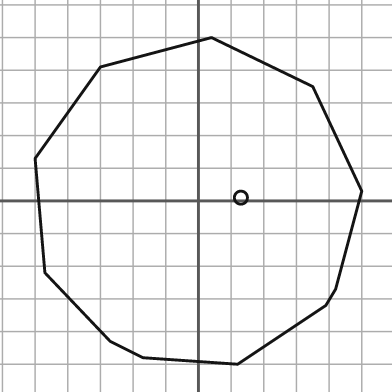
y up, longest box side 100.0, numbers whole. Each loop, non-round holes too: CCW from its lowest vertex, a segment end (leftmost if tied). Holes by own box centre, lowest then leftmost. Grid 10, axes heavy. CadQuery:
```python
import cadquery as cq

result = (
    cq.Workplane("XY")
    .moveTo(12.0, -50.0)
    .lineTo(39.0, -32.0)
    .lineTo(42.0, -27.0)
    .lineTo(50.0, 3.0)
    .lineTo(35.0, 35.0)
    .lineTo(4.0, 50.0)
    .lineTo(-30.0, 41.0)
    .lineTo(-50.0, 13.0)
    .lineTo(-47.0, -22.0)
    .lineTo(-27.0, -43.0)
    .lineTo(-17.0, -48.0)
    .close()
    .moveTo(13.0, 1.0)
    .circle(2.0)
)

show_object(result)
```